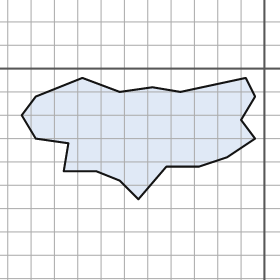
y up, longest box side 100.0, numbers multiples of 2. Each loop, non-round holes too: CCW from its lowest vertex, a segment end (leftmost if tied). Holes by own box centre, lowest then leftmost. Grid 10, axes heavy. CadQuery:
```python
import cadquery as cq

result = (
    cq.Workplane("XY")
    .moveTo(-54.0, -56.0)
    .lineTo(-42.0, -42.0)
    .lineTo(-28.0, -42.0)
    .lineTo(-16.0, -38.0)
    .lineTo(-4.0, -30.0)
    .lineTo(-10.0, -22.0)
    .lineTo(-4.0, -12.0)
    .lineTo(-8.0, -4.0)
    .lineTo(-36.0, -10.0)
    .lineTo(-48.0, -8.0)
    .lineTo(-62.0, -10.0)
    .lineTo(-78.0, -4.0)
    .lineTo(-98.0, -12.0)
    .lineTo(-104.0, -20.0)
    .lineTo(-98.0, -30.0)
    .lineTo(-84.0, -32.0)
    .lineTo(-86.0, -44.0)
    .lineTo(-72.0, -44.0)
    .lineTo(-62.0, -48.0)
    .close()
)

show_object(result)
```